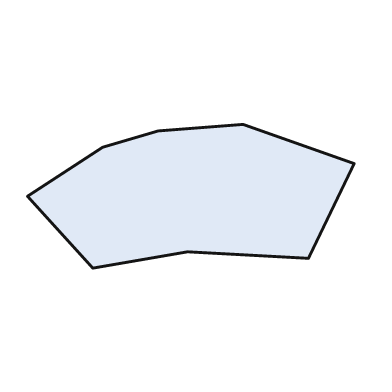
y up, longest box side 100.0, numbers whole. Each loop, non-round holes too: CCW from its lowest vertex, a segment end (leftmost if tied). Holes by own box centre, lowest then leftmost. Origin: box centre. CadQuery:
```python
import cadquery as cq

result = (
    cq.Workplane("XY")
    .moveTo(-30.0, -22.0)
    .lineTo(-1.0, -17.0)
    .lineTo(36.0, -19.0)
    .lineTo(50.0, 10.0)
    .lineTo(16.0, 22.0)
    .lineTo(-10.0, 20.0)
    .lineTo(-27.0, 15.0)
    .lineTo(-50.0, 0.0)
    .close()
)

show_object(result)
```